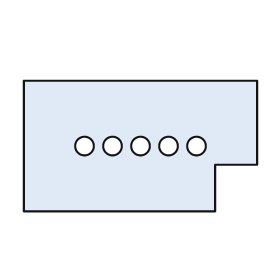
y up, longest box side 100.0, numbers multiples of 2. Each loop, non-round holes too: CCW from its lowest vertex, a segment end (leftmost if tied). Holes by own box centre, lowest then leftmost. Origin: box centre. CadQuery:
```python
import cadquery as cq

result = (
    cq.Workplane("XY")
    .moveTo(-50.0, -28.0)
    .lineTo(32.0, -28.0)
    .lineTo(32.0, -8.0)
    .lineTo(50.0, -8.0)
    .lineTo(50.0, 28.0)
    .lineTo(-50.0, 28.0)
    .close()
    .moveTo(-24.0, 0.0)
    .circle(4.0)
    .moveTo(-12.0, 0.0)
    .circle(4.0)
    .moveTo(0.0, 0.0)
    .circle(4.0)
    .moveTo(12.0, 0.0)
    .circle(4.0)
    .moveTo(24.0, 0.0)
    .circle(4.0)
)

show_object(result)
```